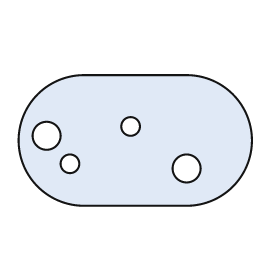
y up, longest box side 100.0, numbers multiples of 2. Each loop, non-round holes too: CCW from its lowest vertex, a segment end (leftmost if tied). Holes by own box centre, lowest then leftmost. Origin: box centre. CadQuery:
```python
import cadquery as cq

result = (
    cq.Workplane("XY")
    .moveTo(-22.0, -28.0)
    .lineTo(22.0, -28.0)
    .threePointArc((50.0, 0.0), (22.0, 28.0))
    .lineTo(-22.0, 28.0)
    .threePointArc((-50.0, 0.0), (-22.0, -28.0))
    .close()
    .moveTo(22.0, -12.0)
    .circle(6.0)
    .moveTo(-28.0, -10.0)
    .circle(4.0)
    .moveTo(-38.0, 2.0)
    .circle(6.0)
    .moveTo(-2.0, 6.0)
    .circle(4.0)
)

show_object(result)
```